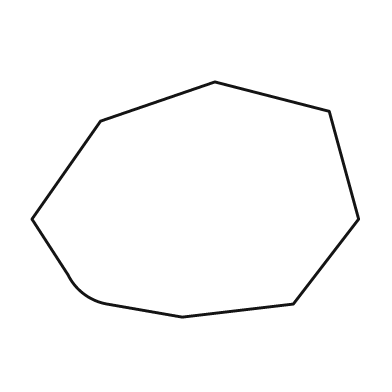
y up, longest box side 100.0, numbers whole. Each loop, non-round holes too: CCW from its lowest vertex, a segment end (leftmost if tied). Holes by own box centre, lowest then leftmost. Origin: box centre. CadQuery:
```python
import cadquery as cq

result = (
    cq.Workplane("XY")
    .moveTo(-4.0, -36.0)
    .lineTo(30.0, -32.0)
    .lineTo(50.0, -6.0)
    .lineTo(41.0, 27.0)
    .lineTo(6.0, 36.0)
    .lineTo(-29.0, 24.0)
    .lineTo(-50.0, -6.0)
    .lineTo(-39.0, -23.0)
    .threePointArc((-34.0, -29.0), (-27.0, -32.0))
    .close()
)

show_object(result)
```